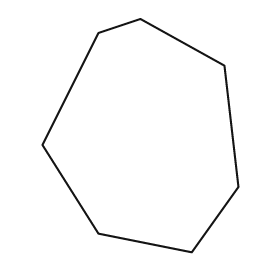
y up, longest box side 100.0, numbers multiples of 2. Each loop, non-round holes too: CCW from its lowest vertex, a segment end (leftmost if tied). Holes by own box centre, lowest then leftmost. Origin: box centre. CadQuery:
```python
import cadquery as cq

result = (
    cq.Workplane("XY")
    .moveTo(22.0, -50.0)
    .lineTo(42.0, -22.0)
    .lineTo(36.0, 30.0)
    .lineTo(0.0, 50.0)
    .lineTo(-18.0, 44.0)
    .lineTo(-42.0, -4.0)
    .lineTo(-18.0, -42.0)
    .close()
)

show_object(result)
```